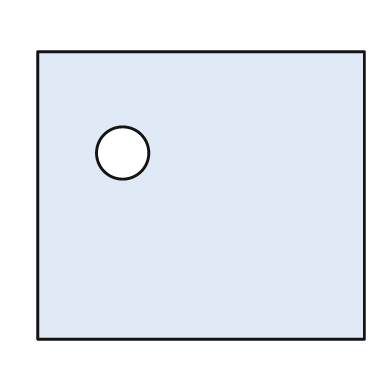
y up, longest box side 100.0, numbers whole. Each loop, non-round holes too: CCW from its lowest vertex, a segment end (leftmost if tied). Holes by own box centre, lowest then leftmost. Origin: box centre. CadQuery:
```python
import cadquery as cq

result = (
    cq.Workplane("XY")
    .moveTo(-50.0, -44.0)
    .lineTo(50.0, -44.0)
    .lineTo(50.0, 44.0)
    .lineTo(-50.0, 44.0)
    .close()
    .moveTo(-24.0, 13.0)
    .circle(8.0)
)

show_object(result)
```